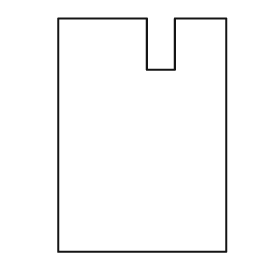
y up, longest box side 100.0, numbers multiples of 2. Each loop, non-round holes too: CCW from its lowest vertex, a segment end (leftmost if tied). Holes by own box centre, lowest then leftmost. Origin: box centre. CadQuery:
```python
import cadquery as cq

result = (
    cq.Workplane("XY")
    .moveTo(-36.0, -50.0)
    .lineTo(36.0, -50.0)
    .lineTo(36.0, 50.0)
    .lineTo(14.0, 50.0)
    .lineTo(14.0, 28.0)
    .lineTo(2.0, 28.0)
    .lineTo(2.0, 50.0)
    .lineTo(-36.0, 50.0)
    .close()
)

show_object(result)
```